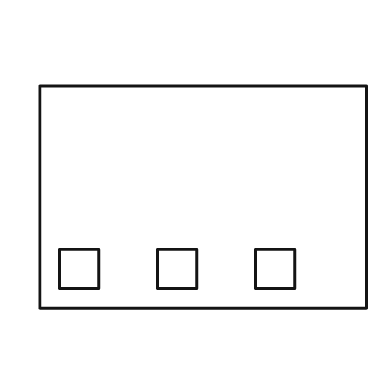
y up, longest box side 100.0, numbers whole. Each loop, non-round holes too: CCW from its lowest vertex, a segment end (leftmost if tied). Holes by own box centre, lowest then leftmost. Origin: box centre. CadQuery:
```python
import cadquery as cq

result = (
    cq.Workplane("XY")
    .moveTo(-50.0, -34.0)
    .lineTo(50.0, -34.0)
    .lineTo(50.0, 34.0)
    .lineTo(-50.0, 34.0)
    .close()
    .moveTo(-44.0, -28.0)
    .lineTo(-32.0, -28.0)
    .lineTo(-32.0, -16.0)
    .lineTo(-44.0, -16.0)
    .close()
    .moveTo(-14.0, -28.0)
    .lineTo(-2.0, -28.0)
    .lineTo(-2.0, -16.0)
    .lineTo(-14.0, -16.0)
    .close()
    .moveTo(16.0, -28.0)
    .lineTo(28.0, -28.0)
    .lineTo(28.0, -16.0)
    .lineTo(16.0, -16.0)
    .close()
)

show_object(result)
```